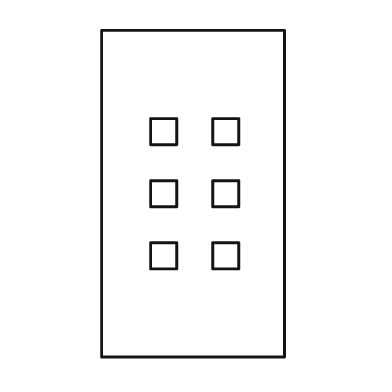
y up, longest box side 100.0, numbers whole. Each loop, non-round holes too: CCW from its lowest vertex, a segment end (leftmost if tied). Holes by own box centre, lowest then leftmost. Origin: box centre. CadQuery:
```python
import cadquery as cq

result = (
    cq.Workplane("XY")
    .moveTo(-28.0, -50.0)
    .lineTo(28.0, -50.0)
    .lineTo(28.0, 50.0)
    .lineTo(-28.0, 50.0)
    .close()
    .moveTo(-13.0, -23.0)
    .lineTo(-5.0, -23.0)
    .lineTo(-5.0, -15.0)
    .lineTo(-13.0, -15.0)
    .close()
    .moveTo(6.0, -23.0)
    .lineTo(14.0, -23.0)
    .lineTo(14.0, -15.0)
    .lineTo(6.0, -15.0)
    .close()
    .moveTo(-13.0, -4.0)
    .lineTo(-5.0, -4.0)
    .lineTo(-5.0, 4.0)
    .lineTo(-13.0, 4.0)
    .close()
    .moveTo(6.0, -4.0)
    .lineTo(14.0, -4.0)
    .lineTo(14.0, 4.0)
    .lineTo(6.0, 4.0)
    .close()
    .moveTo(-13.0, 15.0)
    .lineTo(-5.0, 15.0)
    .lineTo(-5.0, 23.0)
    .lineTo(-13.0, 23.0)
    .close()
    .moveTo(6.0, 15.0)
    .lineTo(14.0, 15.0)
    .lineTo(14.0, 23.0)
    .lineTo(6.0, 23.0)
    .close()
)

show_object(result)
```